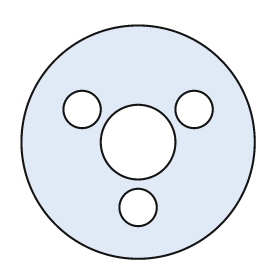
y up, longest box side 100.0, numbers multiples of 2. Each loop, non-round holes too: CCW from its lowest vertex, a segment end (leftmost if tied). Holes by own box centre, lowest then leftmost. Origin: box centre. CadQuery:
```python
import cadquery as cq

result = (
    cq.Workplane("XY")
    .moveTo(0.0, 0.0)
    .circle(50.0)
    .moveTo(0.0, -28.0)
    .circle(8.0)
    .moveTo(0.0, 0.0)
    .circle(16.0)
    .moveTo(-24.0, 14.0)
    .circle(8.0)
    .moveTo(24.0, 14.0)
    .circle(8.0)
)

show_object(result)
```